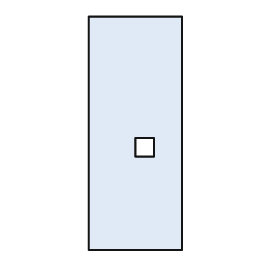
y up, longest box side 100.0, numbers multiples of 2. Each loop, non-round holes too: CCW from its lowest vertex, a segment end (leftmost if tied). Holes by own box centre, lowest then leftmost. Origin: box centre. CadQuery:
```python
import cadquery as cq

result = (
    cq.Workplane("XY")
    .moveTo(-20.0, -50.0)
    .lineTo(20.0, -50.0)
    .lineTo(20.0, 50.0)
    .lineTo(-20.0, 50.0)
    .close()
    .moveTo(0.0, -10.0)
    .lineTo(8.0, -10.0)
    .lineTo(8.0, -2.0)
    .lineTo(0.0, -2.0)
    .close()
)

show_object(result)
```